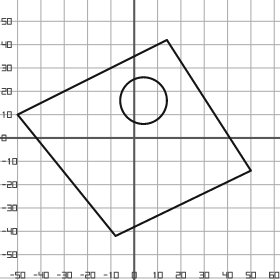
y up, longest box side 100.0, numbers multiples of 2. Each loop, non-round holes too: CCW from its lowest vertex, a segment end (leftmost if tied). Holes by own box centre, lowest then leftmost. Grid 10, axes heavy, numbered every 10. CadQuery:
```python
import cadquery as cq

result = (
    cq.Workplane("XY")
    .moveTo(-8.0, -42.0)
    .lineTo(50.0, -14.0)
    .lineTo(14.0, 42.0)
    .lineTo(-50.0, 10.0)
    .close()
    .moveTo(4.0, 16.0)
    .circle(10.0)
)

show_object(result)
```